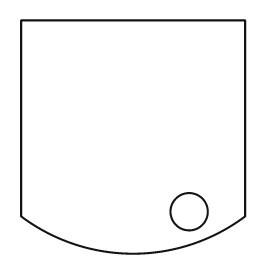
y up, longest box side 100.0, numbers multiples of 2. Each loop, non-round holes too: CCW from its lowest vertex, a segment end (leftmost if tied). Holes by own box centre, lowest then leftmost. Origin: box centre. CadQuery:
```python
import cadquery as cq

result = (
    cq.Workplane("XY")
    .moveTo(-48.0, -34.0)
    .threePointArc((0.0, -50.0), (48.0, -34.0))
    .lineTo(48.0, 50.0)
    .lineTo(-48.0, 50.0)
    .close()
    .moveTo(24.0, -32.0)
    .circle(8.0)
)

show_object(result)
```